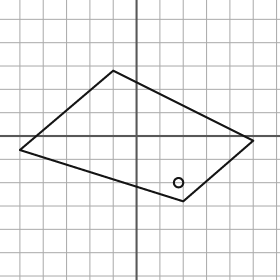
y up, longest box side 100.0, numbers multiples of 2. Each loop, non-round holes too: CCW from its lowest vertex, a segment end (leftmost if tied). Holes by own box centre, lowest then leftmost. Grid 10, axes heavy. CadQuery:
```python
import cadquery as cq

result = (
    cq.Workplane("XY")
    .moveTo(20.0, -28.0)
    .lineTo(50.0, -2.0)
    .lineTo(-10.0, 28.0)
    .lineTo(-50.0, -6.0)
    .close()
    .moveTo(18.0, -20.0)
    .circle(2.0)
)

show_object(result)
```